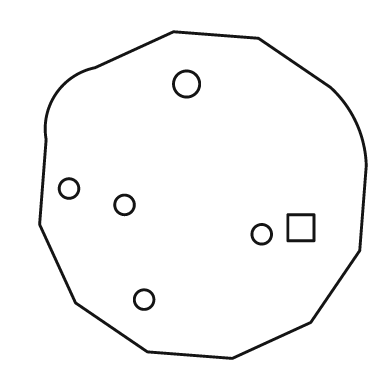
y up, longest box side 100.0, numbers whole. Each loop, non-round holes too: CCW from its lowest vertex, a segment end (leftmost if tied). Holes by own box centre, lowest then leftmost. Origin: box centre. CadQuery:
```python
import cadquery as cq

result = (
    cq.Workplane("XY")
    .moveTo(9.0, -50.0)
    .lineTo(33.0, -39.0)
    .lineTo(48.0, -17.0)
    .lineTo(50.0, 9.0)
    .threePointArc((47.0, 22.0), (39.0, 33.0))
    .lineTo(17.0, 48.0)
    .lineTo(-9.0, 50.0)
    .lineTo(-33.0, 39.0)
    .threePointArc((-45.0, 31.0), (-48.0, 17.0))
    .lineTo(-50.0, -9.0)
    .lineTo(-39.0, -33.0)
    .lineTo(-17.0, -48.0)
    .close()
    .moveTo(-18.0, -32.0)
    .circle(3.0)
    .moveTo(18.0, -12.0)
    .circle(3.0)
    .moveTo(26.0, -14.0)
    .lineTo(34.0, -14.0)
    .lineTo(34.0, -6.0)
    .lineTo(26.0, -6.0)
    .close()
    .moveTo(-24.0, -3.0)
    .circle(3.0)
    .moveTo(-41.0, 2.0)
    .circle(3.0)
    .moveTo(-5.0, 34.0)
    .circle(4.0)
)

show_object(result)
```